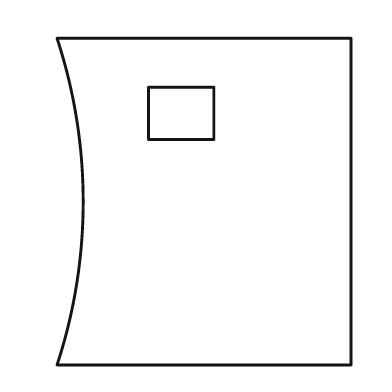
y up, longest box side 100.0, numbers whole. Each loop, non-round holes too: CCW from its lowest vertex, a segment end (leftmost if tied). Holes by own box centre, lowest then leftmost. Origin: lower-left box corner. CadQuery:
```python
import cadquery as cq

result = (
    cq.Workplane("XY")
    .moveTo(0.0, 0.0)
    .lineTo(90.0, 0.0)
    .lineTo(90.0, 100.0)
    .lineTo(0.0, 100.0)
    .threePointArc((8.0, 50.0), (0.0, 0.0))
    .close()
    .moveTo(28.0, 69.0)
    .lineTo(48.0, 69.0)
    .lineTo(48.0, 85.0)
    .lineTo(28.0, 85.0)
    .close()
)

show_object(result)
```